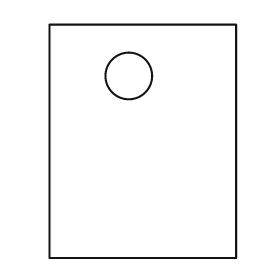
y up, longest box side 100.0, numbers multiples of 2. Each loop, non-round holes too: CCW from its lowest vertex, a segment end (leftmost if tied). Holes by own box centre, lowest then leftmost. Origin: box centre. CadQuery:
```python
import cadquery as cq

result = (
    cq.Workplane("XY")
    .moveTo(-40.0, -50.0)
    .lineTo(40.0, -50.0)
    .lineTo(40.0, 50.0)
    .lineTo(-40.0, 50.0)
    .close()
    .moveTo(-6.0, 28.0)
    .circle(10.0)
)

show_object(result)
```